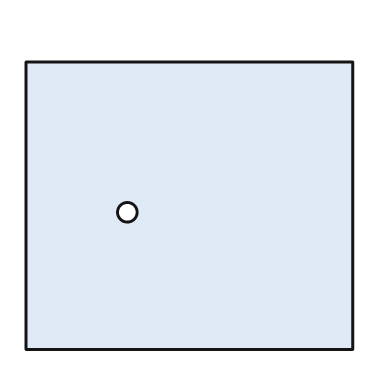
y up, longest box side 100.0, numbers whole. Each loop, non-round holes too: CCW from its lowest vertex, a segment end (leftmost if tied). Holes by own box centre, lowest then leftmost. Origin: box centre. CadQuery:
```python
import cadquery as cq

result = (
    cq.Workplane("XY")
    .moveTo(-50.0, -44.0)
    .lineTo(50.0, -44.0)
    .lineTo(50.0, 44.0)
    .lineTo(-50.0, 44.0)
    .close()
    .moveTo(-19.0, -2.0)
    .circle(3.0)
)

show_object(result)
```